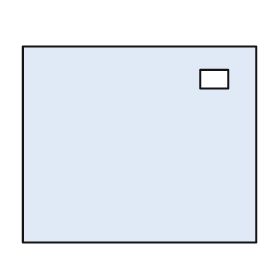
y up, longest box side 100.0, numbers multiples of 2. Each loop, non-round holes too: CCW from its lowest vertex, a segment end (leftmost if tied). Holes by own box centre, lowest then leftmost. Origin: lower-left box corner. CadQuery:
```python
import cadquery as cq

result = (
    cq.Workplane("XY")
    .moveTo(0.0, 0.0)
    .lineTo(100.0, 0.0)
    .lineTo(100.0, 84.0)
    .lineTo(0.0, 84.0)
    .close()
    .moveTo(76.0, 66.0)
    .lineTo(88.0, 66.0)
    .lineTo(88.0, 74.0)
    .lineTo(76.0, 74.0)
    .close()
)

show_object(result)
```